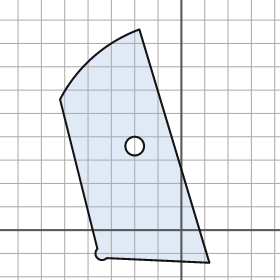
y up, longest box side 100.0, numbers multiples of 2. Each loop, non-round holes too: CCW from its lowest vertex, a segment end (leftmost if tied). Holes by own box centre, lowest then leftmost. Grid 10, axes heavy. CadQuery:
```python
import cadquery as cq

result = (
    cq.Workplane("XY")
    .moveTo(12.0, -14.0)
    .lineTo(-18.0, 86.0)
    .threePointArc((-38.0, 74.0), (-52.0, 56.0))
    .lineTo(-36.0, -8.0)
    .threePointArc((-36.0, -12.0), (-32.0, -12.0))
    .close()
    .moveTo(-20.0, 36.0)
    .circle(4.0)
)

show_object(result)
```